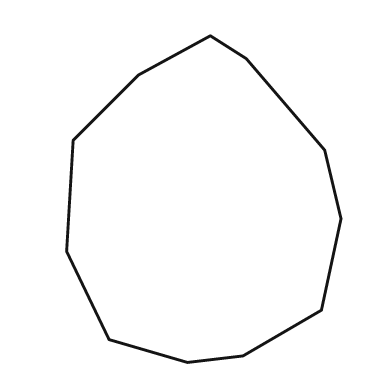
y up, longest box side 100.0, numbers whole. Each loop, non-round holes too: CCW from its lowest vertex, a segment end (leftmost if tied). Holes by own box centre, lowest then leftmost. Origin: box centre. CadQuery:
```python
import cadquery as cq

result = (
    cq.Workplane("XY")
    .moveTo(-5.0, -50.0)
    .lineTo(12.0, -48.0)
    .lineTo(36.0, -34.0)
    .lineTo(42.0, -6.0)
    .lineTo(37.0, 15.0)
    .lineTo(13.0, 43.0)
    .lineTo(2.0, 50.0)
    .lineTo(-20.0, 38.0)
    .lineTo(-40.0, 18.0)
    .lineTo(-42.0, -16.0)
    .lineTo(-29.0, -43.0)
    .close()
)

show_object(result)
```